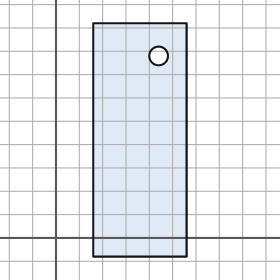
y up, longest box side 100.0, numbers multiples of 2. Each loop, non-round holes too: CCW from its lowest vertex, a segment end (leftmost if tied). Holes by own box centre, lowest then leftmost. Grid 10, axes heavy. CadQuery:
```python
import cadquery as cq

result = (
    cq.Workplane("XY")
    .moveTo(16.0, -8.0)
    .lineTo(56.0, -8.0)
    .lineTo(56.0, 92.0)
    .lineTo(16.0, 92.0)
    .close()
    .moveTo(44.0, 78.0)
    .circle(4.0)
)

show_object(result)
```